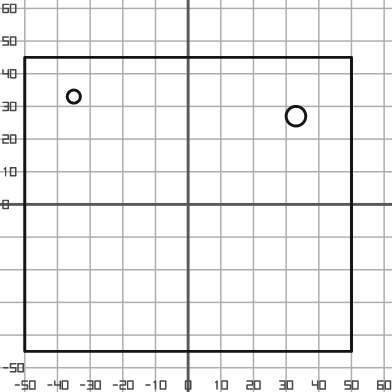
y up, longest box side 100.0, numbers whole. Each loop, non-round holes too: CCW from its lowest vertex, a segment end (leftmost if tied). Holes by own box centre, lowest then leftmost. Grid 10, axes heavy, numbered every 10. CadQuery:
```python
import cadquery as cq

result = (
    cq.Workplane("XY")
    .moveTo(-50.0, -45.0)
    .lineTo(50.0, -45.0)
    .lineTo(50.0, 45.0)
    .lineTo(-50.0, 45.0)
    .close()
    .moveTo(33.0, 27.0)
    .circle(3.0)
    .moveTo(-35.0, 33.0)
    .circle(2.0)
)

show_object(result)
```